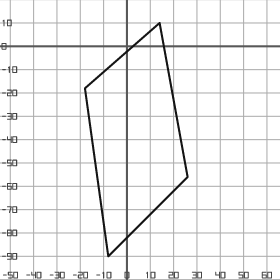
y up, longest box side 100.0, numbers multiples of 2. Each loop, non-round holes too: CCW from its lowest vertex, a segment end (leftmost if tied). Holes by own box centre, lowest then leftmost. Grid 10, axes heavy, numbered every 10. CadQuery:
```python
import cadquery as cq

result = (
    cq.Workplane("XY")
    .moveTo(-8.0, -90.0)
    .lineTo(26.0, -56.0)
    .lineTo(14.0, 10.0)
    .lineTo(-18.0, -18.0)
    .close()
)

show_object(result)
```